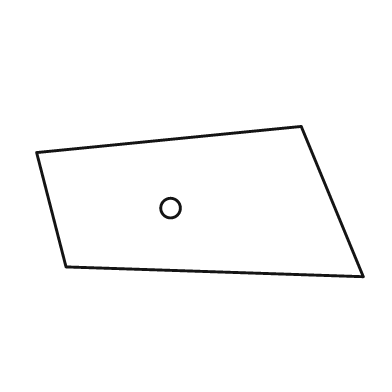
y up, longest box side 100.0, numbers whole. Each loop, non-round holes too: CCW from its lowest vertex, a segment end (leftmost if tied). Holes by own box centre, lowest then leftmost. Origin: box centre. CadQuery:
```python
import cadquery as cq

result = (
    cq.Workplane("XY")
    .moveTo(50.0, -23.0)
    .lineTo(31.0, 23.0)
    .lineTo(-50.0, 15.0)
    .lineTo(-41.0, -20.0)
    .close()
    .moveTo(-9.0, -2.0)
    .circle(3.0)
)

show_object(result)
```